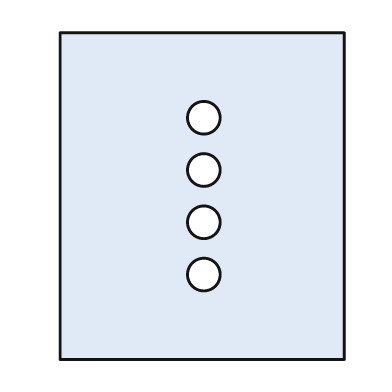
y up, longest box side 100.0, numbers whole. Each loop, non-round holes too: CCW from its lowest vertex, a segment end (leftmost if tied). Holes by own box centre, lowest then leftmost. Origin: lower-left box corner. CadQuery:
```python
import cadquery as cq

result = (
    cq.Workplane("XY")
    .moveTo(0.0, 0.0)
    .lineTo(87.0, 0.0)
    .lineTo(87.0, 100.0)
    .lineTo(0.0, 100.0)
    .close()
    .moveTo(44.0, 26.0)
    .circle(5.0)
    .moveTo(44.0, 42.0)
    .circle(5.0)
    .moveTo(44.0, 58.0)
    .circle(5.0)
    .moveTo(44.0, 74.0)
    .circle(5.0)
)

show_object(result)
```